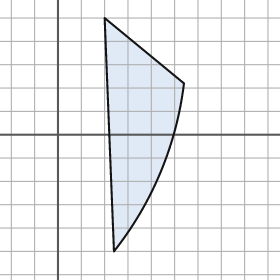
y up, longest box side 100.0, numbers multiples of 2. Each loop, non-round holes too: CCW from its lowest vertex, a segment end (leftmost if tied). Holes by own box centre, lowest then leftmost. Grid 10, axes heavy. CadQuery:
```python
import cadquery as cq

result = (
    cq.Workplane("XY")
    .moveTo(24.0, -50.0)
    .threePointArc((44.0, -16.0), (54.0, 22.0))
    .lineTo(20.0, 50.0)
    .close()
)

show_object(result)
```